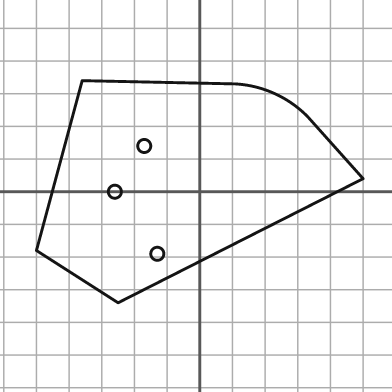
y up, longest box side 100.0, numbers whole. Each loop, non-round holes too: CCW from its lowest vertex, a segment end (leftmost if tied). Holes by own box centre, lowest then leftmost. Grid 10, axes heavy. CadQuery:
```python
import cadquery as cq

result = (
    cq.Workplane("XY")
    .moveTo(-25.0, -34.0)
    .lineTo(50.0, 4.0)
    .lineTo(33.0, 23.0)
    .threePointArc((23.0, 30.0), (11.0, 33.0))
    .lineTo(-36.0, 34.0)
    .lineTo(-50.0, -18.0)
    .close()
    .moveTo(-13.0, -19.0)
    .circle(2.0)
    .moveTo(-26.0, 0.0)
    .circle(2.0)
    .moveTo(-17.0, 14.0)
    .circle(2.0)
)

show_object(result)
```